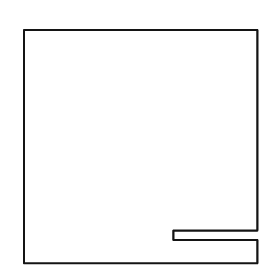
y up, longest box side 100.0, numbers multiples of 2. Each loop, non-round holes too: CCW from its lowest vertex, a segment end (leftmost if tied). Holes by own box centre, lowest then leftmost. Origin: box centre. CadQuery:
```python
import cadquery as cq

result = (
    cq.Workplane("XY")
    .moveTo(-50.0, -50.0)
    .lineTo(50.0, -50.0)
    .lineTo(50.0, -40.0)
    .lineTo(14.0, -40.0)
    .lineTo(14.0, -36.0)
    .lineTo(50.0, -36.0)
    .lineTo(50.0, 50.0)
    .lineTo(-50.0, 50.0)
    .close()
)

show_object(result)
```